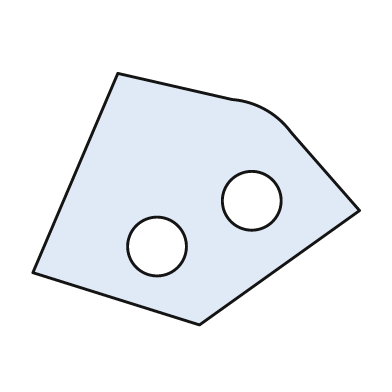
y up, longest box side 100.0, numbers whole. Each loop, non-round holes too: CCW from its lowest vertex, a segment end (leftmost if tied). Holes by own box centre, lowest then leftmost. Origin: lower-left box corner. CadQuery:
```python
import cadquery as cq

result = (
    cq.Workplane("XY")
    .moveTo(51.0, 0.0)
    .lineTo(100.0, 35.0)
    .lineTo(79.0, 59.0)
    .threePointArc((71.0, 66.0), (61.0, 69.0))
    .lineTo(26.0, 77.0)
    .lineTo(0.0, 16.0)
    .close()
    .moveTo(38.0, 24.0)
    .circle(9.0)
    .moveTo(67.0, 38.0)
    .circle(9.0)
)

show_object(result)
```